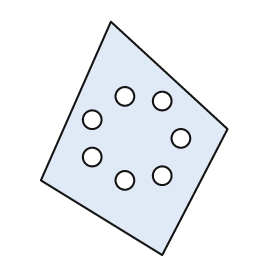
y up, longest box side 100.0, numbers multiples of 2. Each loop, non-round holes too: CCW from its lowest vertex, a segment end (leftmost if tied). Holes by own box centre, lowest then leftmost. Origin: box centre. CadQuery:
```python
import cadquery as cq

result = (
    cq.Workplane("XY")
    .moveTo(12.0, -50.0)
    .lineTo(40.0, 4.0)
    .lineTo(-10.0, 50.0)
    .lineTo(-40.0, -18.0)
    .close()
    .moveTo(-4.0, -18.0)
    .circle(4.0)
    .moveTo(12.0, -16.0)
    .circle(4.0)
    .moveTo(-18.0, -8.0)
    .circle(4.0)
    .moveTo(20.0, 0.0)
    .circle(4.0)
    .moveTo(-18.0, 8.0)
    .circle(4.0)
    .moveTo(12.0, 16.0)
    .circle(4.0)
    .moveTo(-4.0, 18.0)
    .circle(4.0)
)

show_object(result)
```